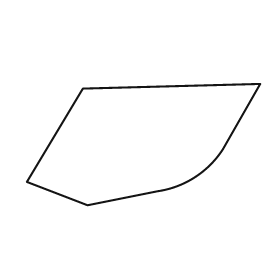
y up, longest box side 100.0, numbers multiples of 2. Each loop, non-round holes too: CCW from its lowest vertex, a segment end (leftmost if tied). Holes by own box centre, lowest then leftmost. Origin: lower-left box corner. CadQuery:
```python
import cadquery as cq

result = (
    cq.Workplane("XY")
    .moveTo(26.0, 0.0)
    .lineTo(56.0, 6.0)
    .threePointArc((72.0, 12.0), (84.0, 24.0))
    .lineTo(100.0, 52.0)
    .lineTo(24.0, 50.0)
    .lineTo(0.0, 10.0)
    .close()
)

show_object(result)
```